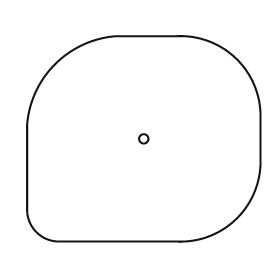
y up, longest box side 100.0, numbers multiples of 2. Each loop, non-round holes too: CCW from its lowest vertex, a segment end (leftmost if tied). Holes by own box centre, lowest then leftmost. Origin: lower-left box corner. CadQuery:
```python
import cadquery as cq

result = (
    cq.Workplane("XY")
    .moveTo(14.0, 0.0)
    .lineTo(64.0, 0.0)
    .threePointArc((90.0, 10.0), (100.0, 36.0))
    .lineTo(100.0, 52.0)
    .threePointArc((90.0, 78.0), (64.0, 88.0))
    .lineTo(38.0, 88.0)
    .threePointArc((12.0, 76.0), (0.0, 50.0))
    .lineTo(0.0, 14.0)
    .threePointArc((4.0, 4.0), (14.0, 0.0))
    .close()
    .moveTo(50.0, 44.0)
    .circle(2.0)
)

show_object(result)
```